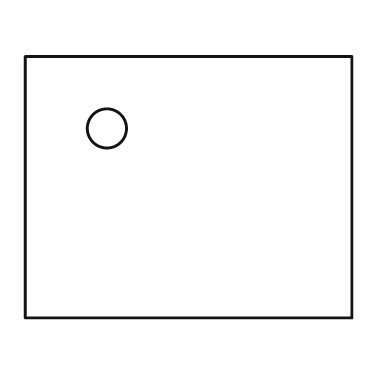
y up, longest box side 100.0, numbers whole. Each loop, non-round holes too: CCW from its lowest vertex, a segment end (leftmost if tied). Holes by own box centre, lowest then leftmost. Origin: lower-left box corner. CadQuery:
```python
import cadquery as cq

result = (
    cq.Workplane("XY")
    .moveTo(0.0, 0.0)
    .lineTo(100.0, 0.0)
    .lineTo(100.0, 80.0)
    .lineTo(0.0, 80.0)
    .close()
    .moveTo(25.0, 58.0)
    .circle(6.0)
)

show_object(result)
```